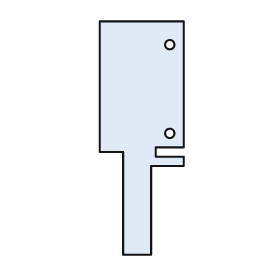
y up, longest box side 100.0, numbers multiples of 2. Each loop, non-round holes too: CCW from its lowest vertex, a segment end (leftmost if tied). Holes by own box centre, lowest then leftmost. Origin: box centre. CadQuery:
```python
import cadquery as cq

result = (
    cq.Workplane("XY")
    .moveTo(-8.0, -50.0)
    .lineTo(4.0, -50.0)
    .lineTo(4.0, -12.0)
    .lineTo(18.0, -12.0)
    .lineTo(18.0, -8.0)
    .lineTo(6.0, -8.0)
    .lineTo(6.0, -4.0)
    .lineTo(18.0, -4.0)
    .lineTo(18.0, 50.0)
    .lineTo(-18.0, 50.0)
    .lineTo(-18.0, -6.0)
    .lineTo(-8.0, -6.0)
    .close()
    .moveTo(12.0, 2.0)
    .circle(2.0)
    .moveTo(12.0, 40.0)
    .circle(2.0)
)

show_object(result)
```